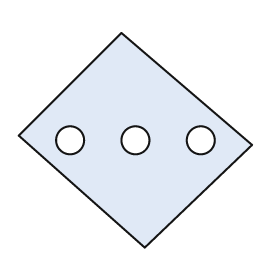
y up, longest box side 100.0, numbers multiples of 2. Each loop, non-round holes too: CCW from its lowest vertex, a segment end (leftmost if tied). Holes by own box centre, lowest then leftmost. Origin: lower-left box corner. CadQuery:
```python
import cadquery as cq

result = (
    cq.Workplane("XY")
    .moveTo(54.0, 0.0)
    .lineTo(100.0, 44.0)
    .lineTo(44.0, 92.0)
    .lineTo(0.0, 48.0)
    .close()
    .moveTo(22.0, 46.0)
    .circle(6.0)
    .moveTo(50.0, 46.0)
    .circle(6.0)
    .moveTo(78.0, 46.0)
    .circle(6.0)
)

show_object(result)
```